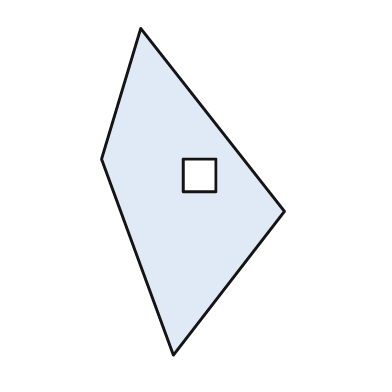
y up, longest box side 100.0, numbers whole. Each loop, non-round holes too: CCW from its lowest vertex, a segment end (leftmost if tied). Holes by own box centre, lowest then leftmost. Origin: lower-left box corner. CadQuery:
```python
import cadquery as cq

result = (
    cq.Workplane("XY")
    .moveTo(22.0, 0.0)
    .lineTo(56.0, 44.0)
    .lineTo(12.0, 100.0)
    .lineTo(0.0, 60.0)
    .close()
    .moveTo(25.0, 50.0)
    .lineTo(35.0, 50.0)
    .lineTo(35.0, 60.0)
    .lineTo(25.0, 60.0)
    .close()
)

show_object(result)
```